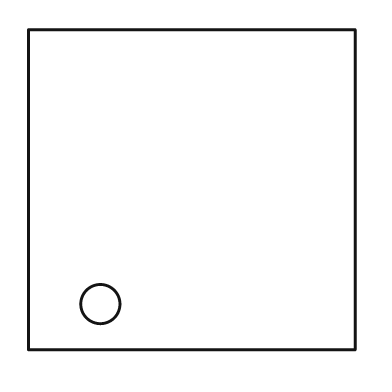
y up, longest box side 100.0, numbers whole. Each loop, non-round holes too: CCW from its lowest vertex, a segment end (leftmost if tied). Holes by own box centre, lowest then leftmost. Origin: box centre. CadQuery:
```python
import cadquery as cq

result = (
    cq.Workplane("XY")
    .moveTo(-50.0, -49.0)
    .lineTo(50.0, -49.0)
    .lineTo(50.0, 49.0)
    .lineTo(-50.0, 49.0)
    .close()
    .moveTo(-28.0, -35.0)
    .circle(6.0)
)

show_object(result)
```